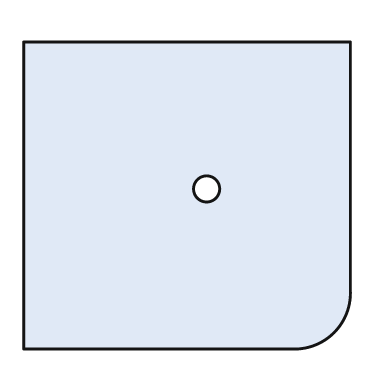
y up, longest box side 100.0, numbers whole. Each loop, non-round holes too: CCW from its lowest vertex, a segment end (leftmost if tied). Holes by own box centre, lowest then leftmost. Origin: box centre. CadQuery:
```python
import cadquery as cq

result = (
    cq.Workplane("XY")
    .moveTo(-50.0, -47.0)
    .lineTo(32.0, -47.0)
    .threePointArc((45.0, -42.0), (50.0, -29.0))
    .lineTo(50.0, 47.0)
    .lineTo(-50.0, 47.0)
    .close()
    .moveTo(6.0, 2.0)
    .circle(4.0)
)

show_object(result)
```